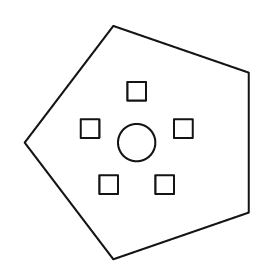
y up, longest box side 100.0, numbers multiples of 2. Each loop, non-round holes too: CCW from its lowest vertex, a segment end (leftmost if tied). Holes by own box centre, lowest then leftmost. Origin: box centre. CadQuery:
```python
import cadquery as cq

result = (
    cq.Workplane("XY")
    .moveTo(-10.0, -50.0)
    .lineTo(48.0, -30.0)
    .lineTo(48.0, 30.0)
    .lineTo(-10.0, 50.0)
    .lineTo(-48.0, 0.0)
    .close()
    .moveTo(-16.0, -22.0)
    .lineTo(-8.0, -22.0)
    .lineTo(-8.0, -14.0)
    .lineTo(-16.0, -14.0)
    .close()
    .moveTo(8.0, -22.0)
    .lineTo(16.0, -22.0)
    .lineTo(16.0, -14.0)
    .lineTo(8.0, -14.0)
    .close()
    .moveTo(0.0, 0.0)
    .circle(8.0)
    .moveTo(-24.0, 2.0)
    .lineTo(-16.0, 2.0)
    .lineTo(-16.0, 10.0)
    .lineTo(-24.0, 10.0)
    .close()
    .moveTo(16.0, 2.0)
    .lineTo(24.0, 2.0)
    .lineTo(24.0, 10.0)
    .lineTo(16.0, 10.0)
    .close()
    .moveTo(-4.0, 18.0)
    .lineTo(4.0, 18.0)
    .lineTo(4.0, 26.0)
    .lineTo(-4.0, 26.0)
    .close()
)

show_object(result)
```